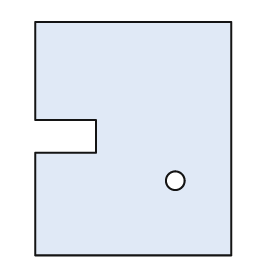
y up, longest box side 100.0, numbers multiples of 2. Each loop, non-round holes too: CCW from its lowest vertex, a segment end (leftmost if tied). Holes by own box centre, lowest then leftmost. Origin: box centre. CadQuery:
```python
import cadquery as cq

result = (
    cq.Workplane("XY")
    .moveTo(-42.0, -50.0)
    .lineTo(42.0, -50.0)
    .lineTo(42.0, 50.0)
    .lineTo(-42.0, 50.0)
    .lineTo(-42.0, 8.0)
    .lineTo(-16.0, 8.0)
    .lineTo(-16.0, -6.0)
    .lineTo(-42.0, -6.0)
    .close()
    .moveTo(18.0, -18.0)
    .circle(4.0)
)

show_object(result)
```